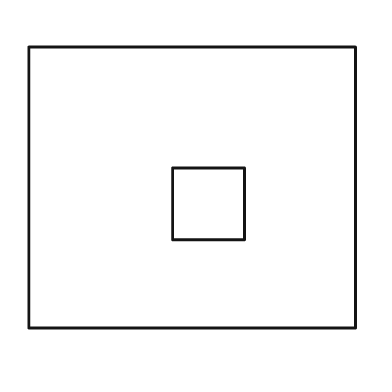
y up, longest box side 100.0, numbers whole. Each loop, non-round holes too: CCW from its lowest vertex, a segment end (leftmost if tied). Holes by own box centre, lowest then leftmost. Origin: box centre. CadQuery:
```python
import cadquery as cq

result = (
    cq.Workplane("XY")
    .moveTo(-50.0, -43.0)
    .lineTo(50.0, -43.0)
    .lineTo(50.0, 43.0)
    .lineTo(-50.0, 43.0)
    .close()
    .moveTo(-6.0, -16.0)
    .lineTo(16.0, -16.0)
    .lineTo(16.0, 6.0)
    .lineTo(-6.0, 6.0)
    .close()
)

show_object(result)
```